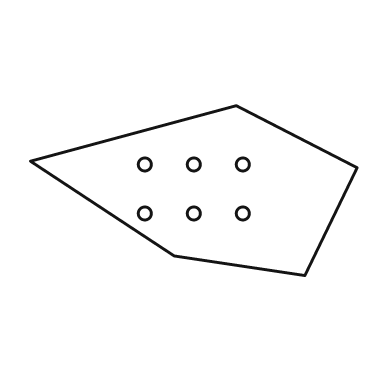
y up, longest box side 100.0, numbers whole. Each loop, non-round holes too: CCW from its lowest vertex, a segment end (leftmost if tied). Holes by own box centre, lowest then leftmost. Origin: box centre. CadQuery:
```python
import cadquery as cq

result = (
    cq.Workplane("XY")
    .moveTo(34.0, -26.0)
    .lineTo(50.0, 7.0)
    .lineTo(13.0, 26.0)
    .lineTo(-50.0, 9.0)
    .lineTo(-6.0, -20.0)
    .close()
    .moveTo(-15.0, -7.0)
    .circle(2.0)
    .moveTo(0.0, -7.0)
    .circle(2.0)
    .moveTo(15.0, -7.0)
    .circle(2.0)
    .moveTo(-15.0, 8.0)
    .circle(2.0)
    .moveTo(0.0, 8.0)
    .circle(2.0)
    .moveTo(15.0, 8.0)
    .circle(2.0)
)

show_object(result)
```